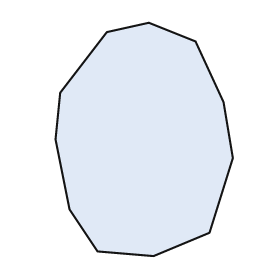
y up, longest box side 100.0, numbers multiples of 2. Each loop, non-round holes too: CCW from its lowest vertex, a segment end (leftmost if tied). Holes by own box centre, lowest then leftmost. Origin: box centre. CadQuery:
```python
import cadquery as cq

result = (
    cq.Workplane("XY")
    .moveTo(4.0, -50.0)
    .lineTo(28.0, -40.0)
    .lineTo(38.0, -8.0)
    .lineTo(34.0, 16.0)
    .lineTo(22.0, 42.0)
    .lineTo(2.0, 50.0)
    .lineTo(-16.0, 46.0)
    .lineTo(-36.0, 20.0)
    .lineTo(-38.0, 0.0)
    .lineTo(-32.0, -30.0)
    .lineTo(-20.0, -48.0)
    .close()
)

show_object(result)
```